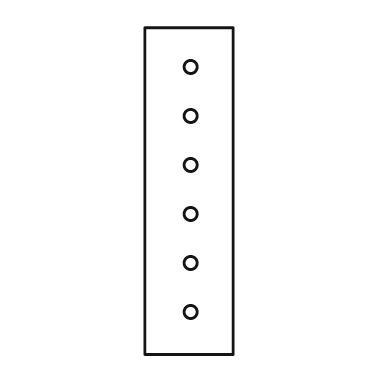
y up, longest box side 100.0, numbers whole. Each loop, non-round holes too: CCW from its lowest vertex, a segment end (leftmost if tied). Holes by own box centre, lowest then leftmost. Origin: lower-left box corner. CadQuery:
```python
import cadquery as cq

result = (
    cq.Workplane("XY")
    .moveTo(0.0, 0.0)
    .lineTo(27.0, 0.0)
    .lineTo(27.0, 100.0)
    .lineTo(0.0, 100.0)
    .close()
    .moveTo(14.0, 13.0)
    .circle(2.0)
    .moveTo(14.0, 28.0)
    .circle(2.0)
    .moveTo(14.0, 43.0)
    .circle(2.0)
    .moveTo(14.0, 58.0)
    .circle(2.0)
    .moveTo(14.0, 73.0)
    .circle(2.0)
    .moveTo(14.0, 88.0)
    .circle(2.0)
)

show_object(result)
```